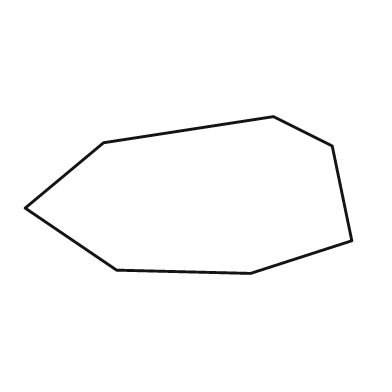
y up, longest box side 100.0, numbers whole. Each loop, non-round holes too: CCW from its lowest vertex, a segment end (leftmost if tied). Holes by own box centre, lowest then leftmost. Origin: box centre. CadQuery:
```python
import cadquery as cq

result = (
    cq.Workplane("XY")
    .moveTo(19.0, -24.0)
    .lineTo(50.0, -14.0)
    .lineTo(44.0, 15.0)
    .lineTo(26.0, 24.0)
    .lineTo(-26.0, 16.0)
    .lineTo(-50.0, -4.0)
    .lineTo(-22.0, -23.0)
    .close()
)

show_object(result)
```